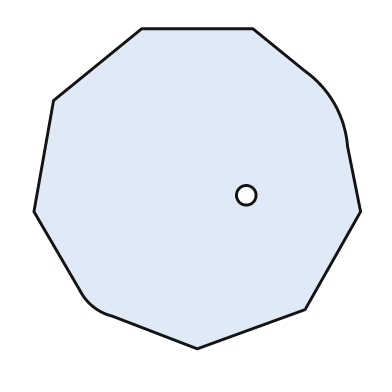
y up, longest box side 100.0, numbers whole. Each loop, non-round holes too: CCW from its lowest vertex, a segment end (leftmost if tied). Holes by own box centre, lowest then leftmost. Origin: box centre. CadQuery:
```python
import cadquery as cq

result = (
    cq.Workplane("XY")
    .moveTo(0.0, -49.0)
    .lineTo(33.0, -37.0)
    .lineTo(50.0, -7.0)
    .lineTo(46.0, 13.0)
    .threePointArc((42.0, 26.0), (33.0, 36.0))
    .lineTo(17.0, 49.0)
    .lineTo(-17.0, 49.0)
    .lineTo(-44.0, 27.0)
    .lineTo(-50.0, -7.0)
    .lineTo(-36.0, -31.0)
    .threePointArc((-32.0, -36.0), (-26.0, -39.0))
    .close()
    .moveTo(15.0, -2.0)
    .circle(3.0)
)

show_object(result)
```